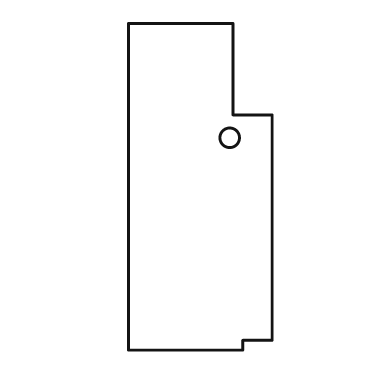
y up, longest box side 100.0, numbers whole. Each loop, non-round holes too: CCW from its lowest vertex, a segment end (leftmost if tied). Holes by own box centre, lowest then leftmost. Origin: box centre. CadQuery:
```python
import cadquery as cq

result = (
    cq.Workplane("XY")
    .moveTo(-22.0, -50.0)
    .lineTo(13.0, -50.0)
    .lineTo(13.0, -47.0)
    .lineTo(22.0, -47.0)
    .lineTo(22.0, 22.0)
    .lineTo(10.0, 22.0)
    .lineTo(10.0, 50.0)
    .lineTo(-22.0, 50.0)
    .close()
    .moveTo(9.0, 15.0)
    .circle(3.0)
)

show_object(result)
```